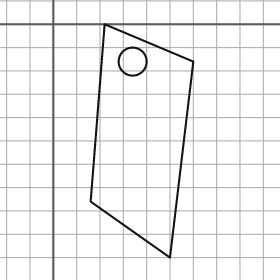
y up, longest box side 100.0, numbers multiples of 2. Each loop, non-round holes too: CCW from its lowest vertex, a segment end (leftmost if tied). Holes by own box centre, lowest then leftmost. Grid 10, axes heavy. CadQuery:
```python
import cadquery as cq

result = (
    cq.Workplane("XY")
    .moveTo(50.0, -100.0)
    .lineTo(60.0, -16.0)
    .lineTo(22.0, 0.0)
    .lineTo(16.0, -76.0)
    .close()
    .moveTo(34.0, -16.0)
    .circle(6.0)
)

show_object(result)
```